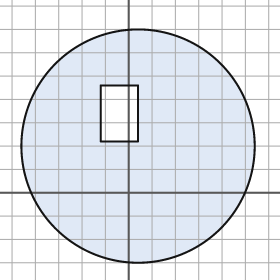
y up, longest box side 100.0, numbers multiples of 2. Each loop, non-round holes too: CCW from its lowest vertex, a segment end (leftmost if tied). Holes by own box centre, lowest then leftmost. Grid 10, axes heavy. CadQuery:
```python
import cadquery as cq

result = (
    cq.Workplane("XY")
    .moveTo(4.0, 20.0)
    .circle(50.0)
    .moveTo(-12.0, 22.0)
    .lineTo(4.0, 22.0)
    .lineTo(4.0, 46.0)
    .lineTo(-12.0, 46.0)
    .close()
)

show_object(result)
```